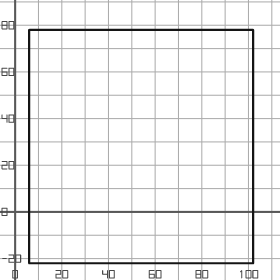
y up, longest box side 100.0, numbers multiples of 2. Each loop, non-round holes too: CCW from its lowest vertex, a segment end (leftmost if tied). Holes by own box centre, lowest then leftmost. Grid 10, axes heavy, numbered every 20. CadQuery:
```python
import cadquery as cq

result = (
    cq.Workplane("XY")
    .moveTo(6.0, -22.0)
    .lineTo(102.0, -22.0)
    .lineTo(102.0, 78.0)
    .lineTo(6.0, 78.0)
    .close()
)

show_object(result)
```